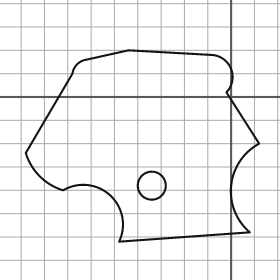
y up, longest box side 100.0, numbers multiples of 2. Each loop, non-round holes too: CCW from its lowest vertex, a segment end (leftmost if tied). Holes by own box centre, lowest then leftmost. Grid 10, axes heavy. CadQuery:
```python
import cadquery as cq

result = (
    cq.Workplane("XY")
    .moveTo(-48.0, -62.0)
    .lineTo(8.0, -58.0)
    .threePointArc((0.0, -38.0), (12.0, -20.0))
    .lineTo(-2.0, 2.0)
    .threePointArc((0.0, 12.0), (-8.0, 18.0))
    .lineTo(-44.0, 20.0)
    .lineTo(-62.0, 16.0)
    .threePointArc((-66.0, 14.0), (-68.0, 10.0))
    .lineTo(-88.0, -24.0)
    .threePointArc((-82.0, -34.0), (-72.0, -40.0))
    .threePointArc((-52.0, -42.0), (-48.0, -62.0))
    .close()
    .moveTo(-34.0, -38.0)
    .circle(6.0)
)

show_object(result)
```